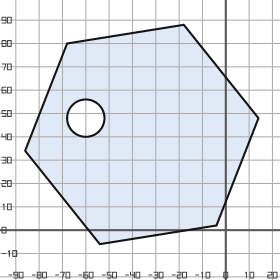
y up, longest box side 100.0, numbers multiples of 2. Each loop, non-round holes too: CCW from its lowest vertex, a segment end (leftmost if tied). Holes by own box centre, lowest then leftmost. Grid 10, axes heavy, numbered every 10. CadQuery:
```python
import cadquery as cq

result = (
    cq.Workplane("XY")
    .moveTo(-54.0, -6.0)
    .lineTo(-4.0, 2.0)
    .lineTo(14.0, 48.0)
    .lineTo(-18.0, 88.0)
    .lineTo(-68.0, 80.0)
    .lineTo(-86.0, 34.0)
    .close()
    .moveTo(-60.0, 48.0)
    .circle(8.0)
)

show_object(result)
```